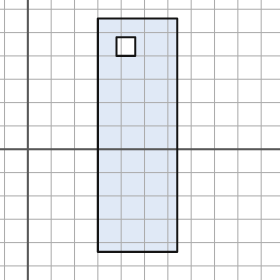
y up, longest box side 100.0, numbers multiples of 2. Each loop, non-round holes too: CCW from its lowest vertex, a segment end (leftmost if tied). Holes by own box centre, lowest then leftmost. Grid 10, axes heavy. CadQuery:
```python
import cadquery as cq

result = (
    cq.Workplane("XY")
    .moveTo(30.0, -44.0)
    .lineTo(64.0, -44.0)
    .lineTo(64.0, 56.0)
    .lineTo(30.0, 56.0)
    .close()
    .moveTo(38.0, 40.0)
    .lineTo(46.0, 40.0)
    .lineTo(46.0, 48.0)
    .lineTo(38.0, 48.0)
    .close()
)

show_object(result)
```